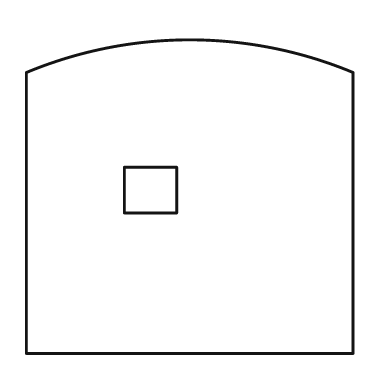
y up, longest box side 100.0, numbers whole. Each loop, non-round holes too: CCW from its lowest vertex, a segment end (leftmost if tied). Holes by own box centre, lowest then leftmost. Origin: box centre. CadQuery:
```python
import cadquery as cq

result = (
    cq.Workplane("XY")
    .moveTo(-50.0, -48.0)
    .lineTo(50.0, -48.0)
    .lineTo(50.0, 38.0)
    .threePointArc((0.0, 48.0), (-50.0, 38.0))
    .close()
    .moveTo(-20.0, -5.0)
    .lineTo(-4.0, -5.0)
    .lineTo(-4.0, 9.0)
    .lineTo(-20.0, 9.0)
    .close()
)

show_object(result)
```